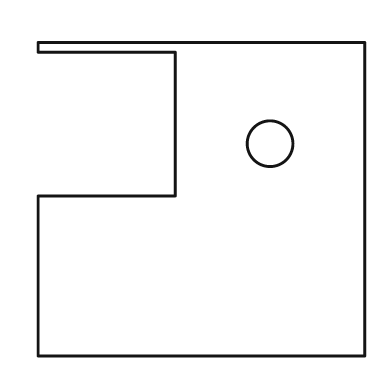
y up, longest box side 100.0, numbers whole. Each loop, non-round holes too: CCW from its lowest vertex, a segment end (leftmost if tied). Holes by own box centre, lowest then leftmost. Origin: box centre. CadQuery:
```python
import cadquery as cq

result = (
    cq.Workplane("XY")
    .moveTo(-50.0, -48.0)
    .lineTo(50.0, -48.0)
    .lineTo(50.0, 48.0)
    .lineTo(-50.0, 48.0)
    .lineTo(-50.0, 45.0)
    .lineTo(-8.0, 45.0)
    .lineTo(-8.0, 1.0)
    .lineTo(-50.0, 1.0)
    .close()
    .moveTo(21.0, 17.0)
    .circle(7.0)
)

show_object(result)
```